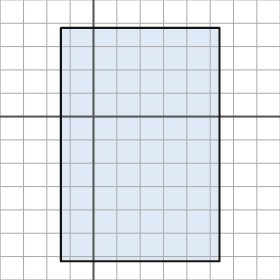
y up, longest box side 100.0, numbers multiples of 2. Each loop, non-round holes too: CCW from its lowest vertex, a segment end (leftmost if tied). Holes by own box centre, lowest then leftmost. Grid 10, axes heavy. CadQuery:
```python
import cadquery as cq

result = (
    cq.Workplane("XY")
    .moveTo(-14.0, -62.0)
    .lineTo(54.0, -62.0)
    .lineTo(54.0, 38.0)
    .lineTo(-14.0, 38.0)
    .close()
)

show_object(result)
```